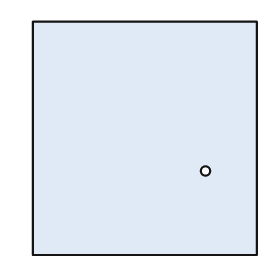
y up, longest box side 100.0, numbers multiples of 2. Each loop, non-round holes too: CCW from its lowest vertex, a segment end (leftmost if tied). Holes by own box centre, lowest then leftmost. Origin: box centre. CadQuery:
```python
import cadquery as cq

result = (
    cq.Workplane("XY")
    .moveTo(-48.0, -50.0)
    .lineTo(48.0, -50.0)
    .lineTo(48.0, 50.0)
    .lineTo(-48.0, 50.0)
    .close()
    .moveTo(26.0, -14.0)
    .circle(2.0)
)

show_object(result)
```